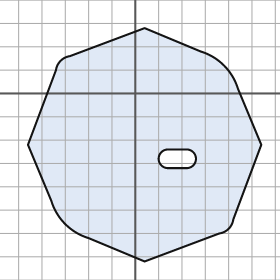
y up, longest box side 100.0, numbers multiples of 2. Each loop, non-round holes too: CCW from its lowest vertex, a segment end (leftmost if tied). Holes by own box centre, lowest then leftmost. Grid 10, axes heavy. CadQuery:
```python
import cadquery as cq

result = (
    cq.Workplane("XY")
    .moveTo(4.0, -72.0)
    .lineTo(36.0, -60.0)
    .threePointArc((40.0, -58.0), (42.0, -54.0))
    .lineTo(54.0, -22.0)
    .lineTo(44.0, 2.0)
    .threePointArc((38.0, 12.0), (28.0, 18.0))
    .lineTo(4.0, 28.0)
    .lineTo(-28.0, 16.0)
    .threePointArc((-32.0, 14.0), (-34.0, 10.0))
    .lineTo(-46.0, -22.0)
    .lineTo(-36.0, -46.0)
    .threePointArc((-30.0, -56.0), (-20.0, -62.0))
    .close()
    .moveTo(14.0, -32.0)
    .lineTo(22.0, -32.0)
    .threePointArc((26.0, -28.0), (22.0, -24.0))
    .lineTo(14.0, -24.0)
    .threePointArc((10.0, -28.0), (14.0, -32.0))
    .close()
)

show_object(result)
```